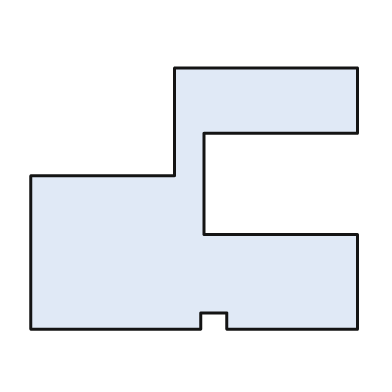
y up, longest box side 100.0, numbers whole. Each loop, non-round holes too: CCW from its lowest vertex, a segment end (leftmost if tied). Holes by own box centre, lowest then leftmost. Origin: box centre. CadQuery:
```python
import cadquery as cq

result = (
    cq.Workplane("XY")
    .moveTo(-50.0, -40.0)
    .lineTo(2.0, -40.0)
    .lineTo(2.0, -35.0)
    .lineTo(10.0, -35.0)
    .lineTo(10.0, -40.0)
    .lineTo(50.0, -40.0)
    .lineTo(50.0, -11.0)
    .lineTo(3.0, -11.0)
    .lineTo(3.0, 20.0)
    .lineTo(50.0, 20.0)
    .lineTo(50.0, 40.0)
    .lineTo(-6.0, 40.0)
    .lineTo(-6.0, 7.0)
    .lineTo(-50.0, 7.0)
    .close()
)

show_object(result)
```